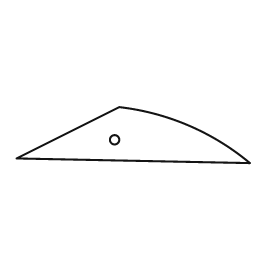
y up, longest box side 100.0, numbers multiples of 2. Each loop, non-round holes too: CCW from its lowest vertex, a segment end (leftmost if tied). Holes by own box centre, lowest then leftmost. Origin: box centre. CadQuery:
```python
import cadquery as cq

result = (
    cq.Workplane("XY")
    .moveTo(50.0, -12.0)
    .threePointArc((24.0, 4.0), (-6.0, 12.0))
    .lineTo(-50.0, -10.0)
    .close()
    .moveTo(-8.0, -2.0)
    .circle(2.0)
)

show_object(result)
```